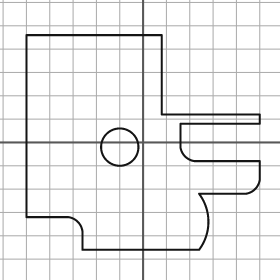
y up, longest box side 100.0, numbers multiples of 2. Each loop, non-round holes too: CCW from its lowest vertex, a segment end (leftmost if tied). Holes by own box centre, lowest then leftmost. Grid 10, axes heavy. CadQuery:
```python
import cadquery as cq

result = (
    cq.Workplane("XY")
    .moveTo(-26.0, -46.0)
    .lineTo(24.0, -46.0)
    .threePointArc((28.0, -34.0), (24.0, -22.0))
    .lineTo(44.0, -22.0)
    .threePointArc((48.0, -20.0), (50.0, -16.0))
    .lineTo(50.0, -8.0)
    .lineTo(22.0, -8.0)
    .threePointArc((18.0, -6.0), (16.0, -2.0))
    .lineTo(16.0, 8.0)
    .lineTo(50.0, 8.0)
    .lineTo(50.0, 12.0)
    .lineTo(8.0, 12.0)
    .lineTo(8.0, 46.0)
    .lineTo(-50.0, 46.0)
    .lineTo(-50.0, -32.0)
    .lineTo(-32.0, -32.0)
    .threePointArc((-28.0, -34.0), (-26.0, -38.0))
    .close()
    .moveTo(-10.0, -2.0)
    .circle(8.0)
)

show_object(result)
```